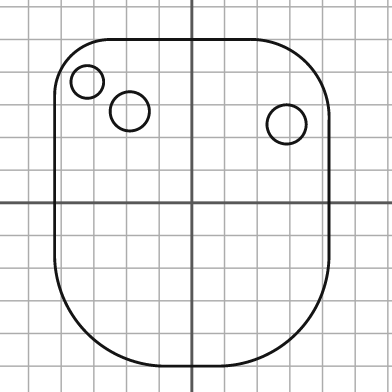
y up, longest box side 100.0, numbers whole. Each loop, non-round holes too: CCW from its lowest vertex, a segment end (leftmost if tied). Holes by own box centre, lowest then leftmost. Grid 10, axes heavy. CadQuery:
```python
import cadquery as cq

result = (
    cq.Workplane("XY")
    .moveTo(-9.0, -50.0)
    .lineTo(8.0, -50.0)
    .threePointArc((32.0, -40.0), (42.0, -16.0))
    .lineTo(42.0, 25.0)
    .threePointArc((35.0, 43.0), (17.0, 50.0))
    .lineTo(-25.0, 50.0)
    .threePointArc((-37.0, 45.0), (-42.0, 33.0))
    .lineTo(-42.0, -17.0)
    .threePointArc((-32.0, -40.0), (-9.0, -50.0))
    .close()
    .moveTo(29.0, 24.0)
    .circle(6.0)
    .moveTo(-19.0, 28.0)
    .circle(6.0)
    .moveTo(-32.0, 37.0)
    .circle(5.0)
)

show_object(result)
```